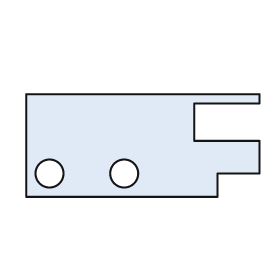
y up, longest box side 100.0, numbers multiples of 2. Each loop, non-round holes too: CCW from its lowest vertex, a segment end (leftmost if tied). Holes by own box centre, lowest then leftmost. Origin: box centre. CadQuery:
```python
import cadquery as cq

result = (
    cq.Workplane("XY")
    .moveTo(-50.0, -22.0)
    .lineTo(32.0, -22.0)
    .lineTo(32.0, -12.0)
    .lineTo(50.0, -12.0)
    .lineTo(50.0, 2.0)
    .lineTo(22.0, 2.0)
    .lineTo(22.0, 18.0)
    .lineTo(50.0, 18.0)
    .lineTo(50.0, 22.0)
    .lineTo(-50.0, 22.0)
    .close()
    .moveTo(-40.0, -12.0)
    .circle(6.0)
    .moveTo(-8.0, -12.0)
    .circle(6.0)
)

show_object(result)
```